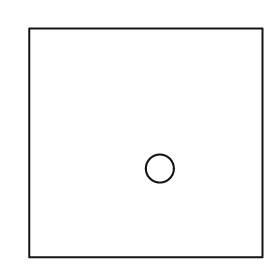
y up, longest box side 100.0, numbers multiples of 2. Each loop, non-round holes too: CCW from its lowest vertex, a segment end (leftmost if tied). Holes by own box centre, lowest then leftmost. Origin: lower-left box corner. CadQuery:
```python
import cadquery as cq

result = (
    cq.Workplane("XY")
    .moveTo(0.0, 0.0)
    .lineTo(100.0, 0.0)
    .lineTo(100.0, 98.0)
    .lineTo(0.0, 98.0)
    .close()
    .moveTo(56.0, 38.0)
    .circle(6.0)
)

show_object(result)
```